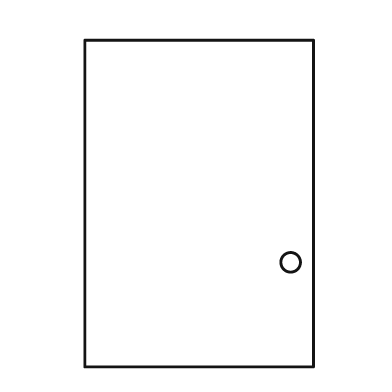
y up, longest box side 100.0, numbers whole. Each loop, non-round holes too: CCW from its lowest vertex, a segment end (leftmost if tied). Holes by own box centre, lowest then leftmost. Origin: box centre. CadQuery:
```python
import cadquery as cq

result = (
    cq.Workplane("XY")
    .moveTo(-35.0, -50.0)
    .lineTo(35.0, -50.0)
    .lineTo(35.0, 50.0)
    .lineTo(-35.0, 50.0)
    .close()
    .moveTo(28.0, -18.0)
    .circle(3.0)
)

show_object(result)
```